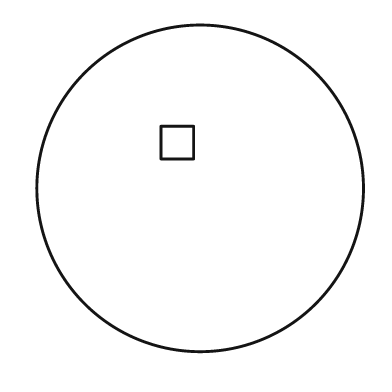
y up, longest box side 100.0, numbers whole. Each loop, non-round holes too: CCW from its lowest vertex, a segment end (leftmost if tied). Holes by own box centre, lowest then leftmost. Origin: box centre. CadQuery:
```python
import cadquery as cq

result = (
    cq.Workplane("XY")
    .moveTo(0.0, 0.0)
    .circle(50.0)
    .moveTo(-12.0, 9.0)
    .lineTo(-2.0, 9.0)
    .lineTo(-2.0, 19.0)
    .lineTo(-12.0, 19.0)
    .close()
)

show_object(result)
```